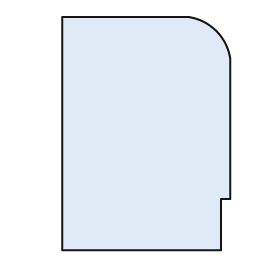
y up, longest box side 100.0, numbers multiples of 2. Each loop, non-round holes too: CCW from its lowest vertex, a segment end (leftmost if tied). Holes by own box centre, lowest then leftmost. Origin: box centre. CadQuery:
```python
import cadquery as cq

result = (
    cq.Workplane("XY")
    .moveTo(-36.0, -50.0)
    .lineTo(32.0, -50.0)
    .lineTo(32.0, -28.0)
    .lineTo(36.0, -28.0)
    .lineTo(36.0, 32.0)
    .threePointArc((30.0, 44.0), (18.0, 50.0))
    .lineTo(-36.0, 50.0)
    .close()
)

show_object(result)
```